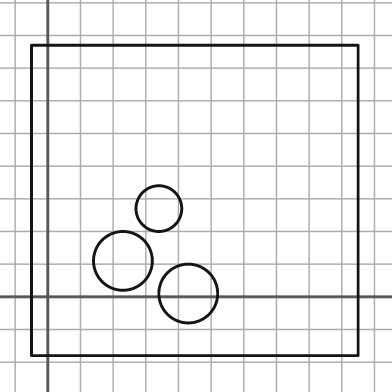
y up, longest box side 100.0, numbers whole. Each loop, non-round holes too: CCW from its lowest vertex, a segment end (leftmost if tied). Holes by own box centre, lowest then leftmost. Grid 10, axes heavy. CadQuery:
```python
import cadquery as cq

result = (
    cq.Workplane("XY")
    .moveTo(-5.0, -18.0)
    .lineTo(95.0, -18.0)
    .lineTo(95.0, 77.0)
    .lineTo(-5.0, 77.0)
    .close()
    .moveTo(43.0, 1.0)
    .circle(9.0)
    .moveTo(23.0, 11.0)
    .circle(9.0)
    .moveTo(34.0, 27.0)
    .circle(7.0)
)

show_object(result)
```